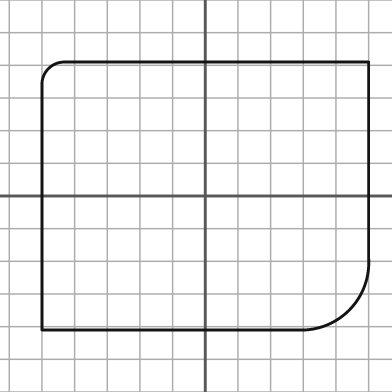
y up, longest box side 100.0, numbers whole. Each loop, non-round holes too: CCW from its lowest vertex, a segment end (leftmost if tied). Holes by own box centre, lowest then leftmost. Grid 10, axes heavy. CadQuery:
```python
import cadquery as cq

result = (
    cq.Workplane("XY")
    .moveTo(-50.0, -41.0)
    .lineTo(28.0, -41.0)
    .threePointArc((44.0, -35.0), (50.0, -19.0))
    .lineTo(50.0, 41.0)
    .lineTo(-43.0, 41.0)
    .threePointArc((-48.0, 39.0), (-50.0, 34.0))
    .close()
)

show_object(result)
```